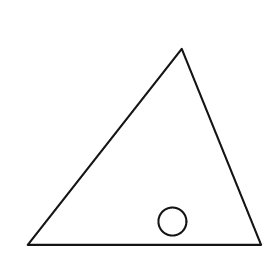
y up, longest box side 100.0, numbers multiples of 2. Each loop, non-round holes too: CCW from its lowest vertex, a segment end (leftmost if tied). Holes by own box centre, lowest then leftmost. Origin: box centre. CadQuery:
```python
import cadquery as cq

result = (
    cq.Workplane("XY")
    .moveTo(-50.0, -42.0)
    .lineTo(50.0, -42.0)
    .lineTo(16.0, 42.0)
    .close()
    .moveTo(12.0, -32.0)
    .circle(6.0)
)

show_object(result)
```